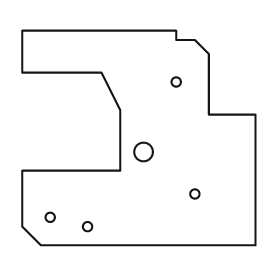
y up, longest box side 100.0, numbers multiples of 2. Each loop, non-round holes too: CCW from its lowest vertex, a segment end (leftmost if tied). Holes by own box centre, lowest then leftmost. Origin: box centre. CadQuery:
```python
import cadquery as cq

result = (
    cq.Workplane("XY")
    .moveTo(-42.0, -46.0)
    .lineTo(50.0, -46.0)
    .lineTo(50.0, 10.0)
    .lineTo(30.0, 10.0)
    .lineTo(30.0, 36.0)
    .lineTo(24.0, 42.0)
    .lineTo(16.0, 42.0)
    .lineTo(16.0, 46.0)
    .lineTo(-50.0, 46.0)
    .lineTo(-50.0, 28.0)
    .lineTo(-16.0, 28.0)
    .lineTo(-8.0, 12.0)
    .lineTo(-8.0, -14.0)
    .lineTo(-50.0, -14.0)
    .lineTo(-50.0, -38.0)
    .close()
    .moveTo(-22.0, -38.0)
    .circle(2.0)
    .moveTo(-38.0, -34.0)
    .circle(2.0)
    .moveTo(24.0, -24.0)
    .circle(2.0)
    .moveTo(2.0, -6.0)
    .circle(4.0)
    .moveTo(16.0, 24.0)
    .circle(2.0)
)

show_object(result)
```